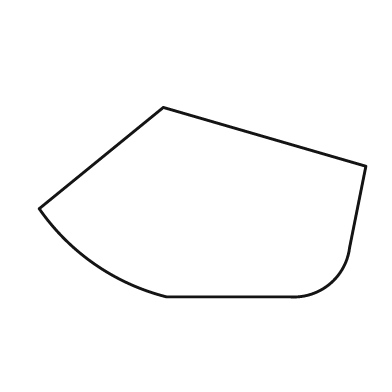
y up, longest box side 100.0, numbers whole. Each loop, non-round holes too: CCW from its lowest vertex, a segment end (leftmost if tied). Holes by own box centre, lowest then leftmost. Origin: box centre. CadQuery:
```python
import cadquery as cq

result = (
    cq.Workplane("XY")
    .moveTo(-11.0, -29.0)
    .lineTo(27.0, -29.0)
    .threePointArc((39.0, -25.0), (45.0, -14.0))
    .lineTo(50.0, 11.0)
    .lineTo(-12.0, 29.0)
    .lineTo(-50.0, -2.0)
    .threePointArc((-33.0, -19.0), (-11.0, -29.0))
    .close()
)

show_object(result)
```